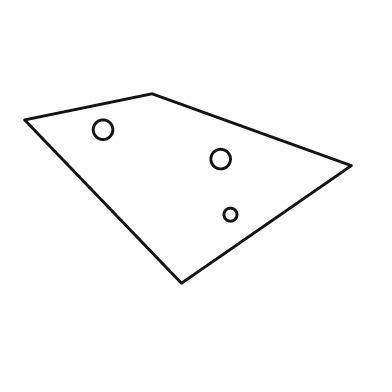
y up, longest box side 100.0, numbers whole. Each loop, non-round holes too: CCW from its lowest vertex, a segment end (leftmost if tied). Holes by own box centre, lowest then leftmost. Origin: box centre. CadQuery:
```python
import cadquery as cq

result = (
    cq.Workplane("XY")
    .moveTo(-2.0, -29.0)
    .lineTo(50.0, 7.0)
    .lineTo(-11.0, 29.0)
    .lineTo(-50.0, 21.0)
    .close()
    .moveTo(13.0, -8.0)
    .circle(2.0)
    .moveTo(10.0, 9.0)
    .circle(3.0)
    .moveTo(-26.0, 18.0)
    .circle(3.0)
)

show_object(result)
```